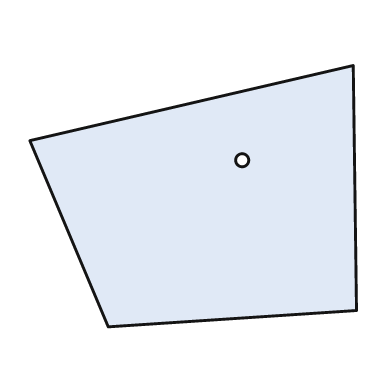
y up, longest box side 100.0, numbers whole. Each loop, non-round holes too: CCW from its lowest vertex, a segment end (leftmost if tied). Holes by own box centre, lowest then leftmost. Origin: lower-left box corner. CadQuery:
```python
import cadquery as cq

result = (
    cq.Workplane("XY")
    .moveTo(24.0, 0.0)
    .lineTo(100.0, 5.0)
    .lineTo(99.0, 80.0)
    .lineTo(0.0, 57.0)
    .close()
    .moveTo(65.0, 51.0)
    .circle(2.0)
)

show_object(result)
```